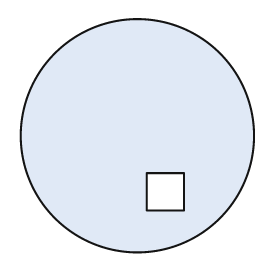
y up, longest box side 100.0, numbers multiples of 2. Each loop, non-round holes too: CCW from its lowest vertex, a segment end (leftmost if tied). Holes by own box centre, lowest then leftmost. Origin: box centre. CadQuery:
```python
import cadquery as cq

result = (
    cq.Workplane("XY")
    .moveTo(0.0, 0.0)
    .circle(50.0)
    .moveTo(4.0, -32.0)
    .lineTo(20.0, -32.0)
    .lineTo(20.0, -16.0)
    .lineTo(4.0, -16.0)
    .close()
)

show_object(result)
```